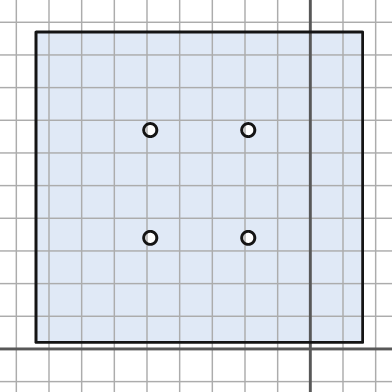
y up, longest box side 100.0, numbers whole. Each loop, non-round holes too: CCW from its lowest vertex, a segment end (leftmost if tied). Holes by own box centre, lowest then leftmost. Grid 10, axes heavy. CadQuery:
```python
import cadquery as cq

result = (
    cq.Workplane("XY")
    .moveTo(-84.0, 2.0)
    .lineTo(16.0, 2.0)
    .lineTo(16.0, 97.0)
    .lineTo(-84.0, 97.0)
    .close()
    .moveTo(-49.0, 34.0)
    .circle(2.0)
    .moveTo(-19.0, 34.0)
    .circle(2.0)
    .moveTo(-49.0, 67.0)
    .circle(2.0)
    .moveTo(-19.0, 67.0)
    .circle(2.0)
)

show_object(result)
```